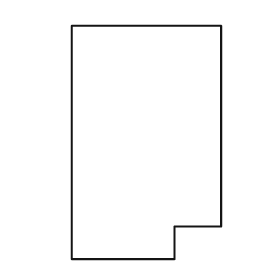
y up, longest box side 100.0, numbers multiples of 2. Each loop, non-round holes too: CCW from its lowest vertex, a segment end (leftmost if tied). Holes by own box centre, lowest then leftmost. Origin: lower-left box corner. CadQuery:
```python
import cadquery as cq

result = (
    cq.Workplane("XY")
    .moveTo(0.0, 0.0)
    .lineTo(44.0, 0.0)
    .lineTo(44.0, 14.0)
    .lineTo(64.0, 14.0)
    .lineTo(64.0, 100.0)
    .lineTo(0.0, 100.0)
    .close()
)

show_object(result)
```